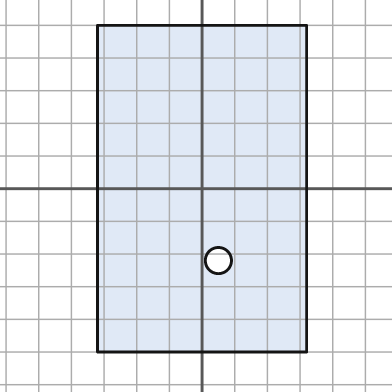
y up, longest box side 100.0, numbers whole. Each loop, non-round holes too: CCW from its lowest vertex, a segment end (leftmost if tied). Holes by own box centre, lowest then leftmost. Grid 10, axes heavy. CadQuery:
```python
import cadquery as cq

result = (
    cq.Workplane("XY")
    .moveTo(-32.0, -50.0)
    .lineTo(32.0, -50.0)
    .lineTo(32.0, 50.0)
    .lineTo(-32.0, 50.0)
    .close()
    .moveTo(5.0, -22.0)
    .circle(4.0)
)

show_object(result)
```